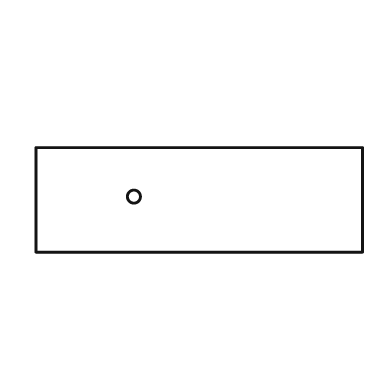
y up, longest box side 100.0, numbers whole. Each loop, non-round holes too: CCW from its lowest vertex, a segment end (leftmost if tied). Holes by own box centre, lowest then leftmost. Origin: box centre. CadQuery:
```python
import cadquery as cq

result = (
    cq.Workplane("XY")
    .moveTo(-50.0, -16.0)
    .lineTo(50.0, -16.0)
    .lineTo(50.0, 16.0)
    .lineTo(-50.0, 16.0)
    .close()
    .moveTo(-20.0, 1.0)
    .circle(2.0)
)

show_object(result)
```